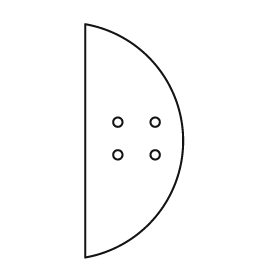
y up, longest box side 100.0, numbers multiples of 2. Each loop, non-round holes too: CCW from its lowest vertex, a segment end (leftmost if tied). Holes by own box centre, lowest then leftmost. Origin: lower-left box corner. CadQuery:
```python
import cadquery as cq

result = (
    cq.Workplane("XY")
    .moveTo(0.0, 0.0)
    .threePointArc((42.0, 50.0), (0.0, 100.0))
    .close()
    .moveTo(14.0, 44.0)
    .circle(2.0)
    .moveTo(30.0, 44.0)
    .circle(2.0)
    .moveTo(14.0, 58.0)
    .circle(2.0)
    .moveTo(30.0, 58.0)
    .circle(2.0)
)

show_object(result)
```